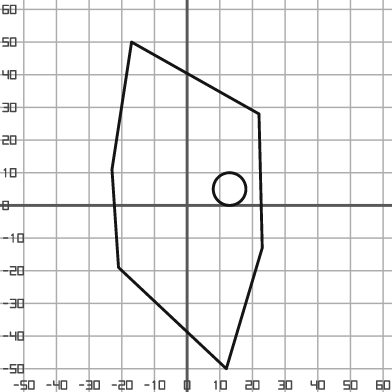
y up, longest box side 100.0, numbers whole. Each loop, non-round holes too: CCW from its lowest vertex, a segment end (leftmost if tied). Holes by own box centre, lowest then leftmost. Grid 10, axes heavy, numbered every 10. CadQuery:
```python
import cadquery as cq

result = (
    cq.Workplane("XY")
    .moveTo(12.0, -50.0)
    .lineTo(23.0, -13.0)
    .lineTo(22.0, 28.0)
    .lineTo(-17.0, 50.0)
    .lineTo(-23.0, 11.0)
    .lineTo(-21.0, -19.0)
    .close()
    .moveTo(13.0, 5.0)
    .circle(5.0)
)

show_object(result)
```